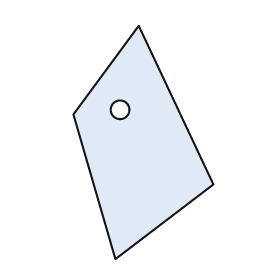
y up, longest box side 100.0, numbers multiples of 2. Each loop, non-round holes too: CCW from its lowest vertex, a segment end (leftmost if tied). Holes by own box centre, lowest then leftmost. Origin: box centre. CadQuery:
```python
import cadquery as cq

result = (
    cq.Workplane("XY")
    .moveTo(-12.0, -50.0)
    .lineTo(30.0, -18.0)
    .lineTo(-2.0, 50.0)
    .lineTo(-30.0, 12.0)
    .close()
    .moveTo(-10.0, 14.0)
    .circle(4.0)
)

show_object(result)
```